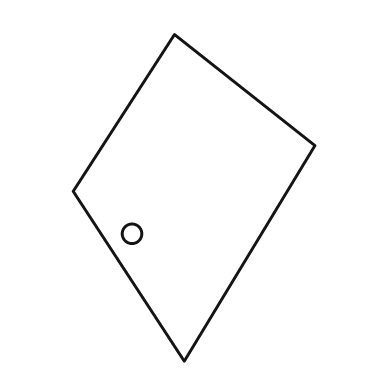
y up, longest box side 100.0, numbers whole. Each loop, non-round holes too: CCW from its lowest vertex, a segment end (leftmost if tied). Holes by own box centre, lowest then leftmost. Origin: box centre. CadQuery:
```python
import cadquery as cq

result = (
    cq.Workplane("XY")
    .moveTo(-3.0, -50.0)
    .lineTo(37.0, 16.0)
    .lineTo(-6.0, 50.0)
    .lineTo(-37.0, 2.0)
    .close()
    .moveTo(-19.0, -11.0)
    .circle(3.0)
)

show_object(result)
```